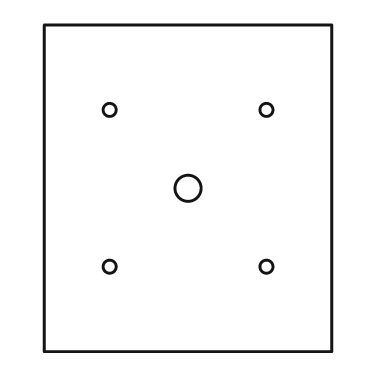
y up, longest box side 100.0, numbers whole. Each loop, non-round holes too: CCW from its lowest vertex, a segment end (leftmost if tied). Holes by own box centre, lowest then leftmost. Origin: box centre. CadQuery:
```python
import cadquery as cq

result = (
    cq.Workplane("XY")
    .moveTo(-44.0, -50.0)
    .lineTo(44.0, -50.0)
    .lineTo(44.0, 50.0)
    .lineTo(-44.0, 50.0)
    .close()
    .moveTo(-24.0, -24.0)
    .circle(2.0)
    .moveTo(24.0, -24.0)
    .circle(2.0)
    .moveTo(0.0, 0.0)
    .circle(4.0)
    .moveTo(-24.0, 24.0)
    .circle(2.0)
    .moveTo(24.0, 24.0)
    .circle(2.0)
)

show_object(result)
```